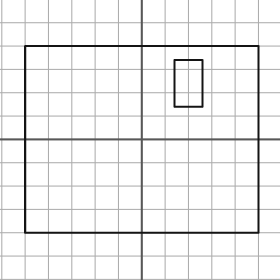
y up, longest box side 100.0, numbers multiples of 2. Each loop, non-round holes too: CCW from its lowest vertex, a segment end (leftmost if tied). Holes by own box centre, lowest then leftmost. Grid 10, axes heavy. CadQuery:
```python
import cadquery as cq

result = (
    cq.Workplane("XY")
    .moveTo(-50.0, -40.0)
    .lineTo(50.0, -40.0)
    .lineTo(50.0, 40.0)
    .lineTo(-50.0, 40.0)
    .close()
    .moveTo(14.0, 14.0)
    .lineTo(26.0, 14.0)
    .lineTo(26.0, 34.0)
    .lineTo(14.0, 34.0)
    .close()
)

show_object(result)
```